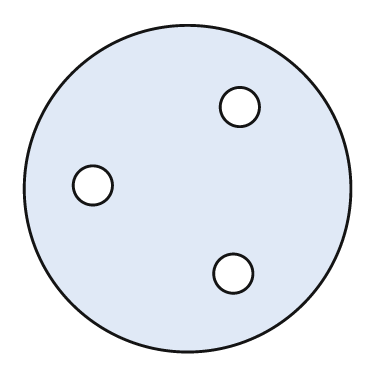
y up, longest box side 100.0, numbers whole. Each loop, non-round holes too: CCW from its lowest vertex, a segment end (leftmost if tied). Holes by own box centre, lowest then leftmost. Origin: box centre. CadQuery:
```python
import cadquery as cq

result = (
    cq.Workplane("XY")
    .moveTo(0.0, 0.0)
    .circle(50.0)
    .moveTo(14.0, -26.0)
    .circle(6.0)
    .moveTo(-29.0, 1.0)
    .circle(6.0)
    .moveTo(16.0, 25.0)
    .circle(6.0)
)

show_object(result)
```